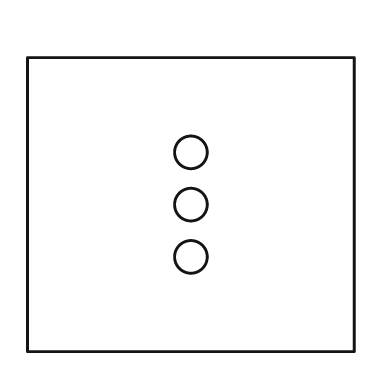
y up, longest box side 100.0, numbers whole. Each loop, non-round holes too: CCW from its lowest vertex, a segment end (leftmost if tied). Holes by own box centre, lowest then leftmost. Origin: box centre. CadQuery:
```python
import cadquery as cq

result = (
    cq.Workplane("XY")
    .moveTo(-50.0, -45.0)
    .lineTo(50.0, -45.0)
    .lineTo(50.0, 45.0)
    .lineTo(-50.0, 45.0)
    .close()
    .moveTo(0.0, -16.0)
    .circle(5.0)
    .moveTo(0.0, 0.0)
    .circle(5.0)
    .moveTo(0.0, 16.0)
    .circle(5.0)
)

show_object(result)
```